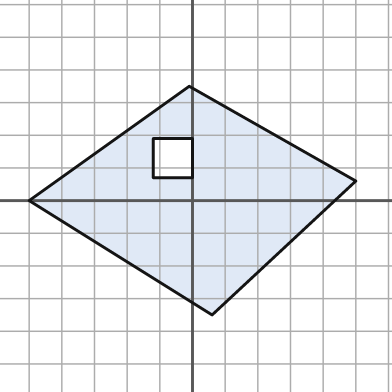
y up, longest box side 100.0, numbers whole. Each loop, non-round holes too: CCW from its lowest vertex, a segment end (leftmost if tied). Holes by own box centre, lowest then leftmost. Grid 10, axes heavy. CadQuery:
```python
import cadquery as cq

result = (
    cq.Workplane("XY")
    .moveTo(6.0, -35.0)
    .lineTo(50.0, 6.0)
    .lineTo(-1.0, 35.0)
    .lineTo(-50.0, 0.0)
    .close()
    .moveTo(-12.0, 7.0)
    .lineTo(0.0, 7.0)
    .lineTo(0.0, 19.0)
    .lineTo(-12.0, 19.0)
    .close()
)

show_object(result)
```